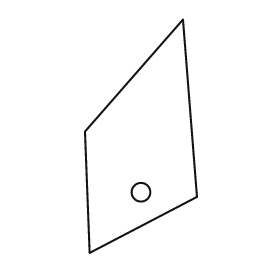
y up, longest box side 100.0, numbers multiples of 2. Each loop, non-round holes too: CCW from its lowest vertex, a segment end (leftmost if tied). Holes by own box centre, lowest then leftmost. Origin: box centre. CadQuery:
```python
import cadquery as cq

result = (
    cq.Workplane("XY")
    .moveTo(-22.0, -50.0)
    .lineTo(24.0, -26.0)
    .lineTo(18.0, 50.0)
    .lineTo(-24.0, 2.0)
    .close()
    .moveTo(0.0, -24.0)
    .circle(4.0)
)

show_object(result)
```